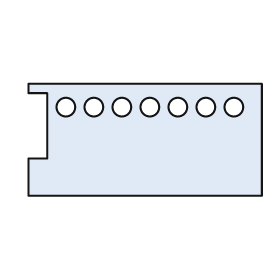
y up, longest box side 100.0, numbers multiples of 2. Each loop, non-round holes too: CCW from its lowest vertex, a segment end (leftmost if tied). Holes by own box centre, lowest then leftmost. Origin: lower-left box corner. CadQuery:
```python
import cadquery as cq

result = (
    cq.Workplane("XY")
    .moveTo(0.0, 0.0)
    .lineTo(100.0, 0.0)
    .lineTo(100.0, 48.0)
    .lineTo(0.0, 48.0)
    .lineTo(0.0, 44.0)
    .lineTo(8.0, 44.0)
    .lineTo(8.0, 16.0)
    .lineTo(0.0, 16.0)
    .close()
    .moveTo(16.0, 38.0)
    .circle(4.0)
    .moveTo(28.0, 38.0)
    .circle(4.0)
    .moveTo(40.0, 38.0)
    .circle(4.0)
    .moveTo(52.0, 38.0)
    .circle(4.0)
    .moveTo(64.0, 38.0)
    .circle(4.0)
    .moveTo(76.0, 38.0)
    .circle(4.0)
    .moveTo(88.0, 38.0)
    .circle(4.0)
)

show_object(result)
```